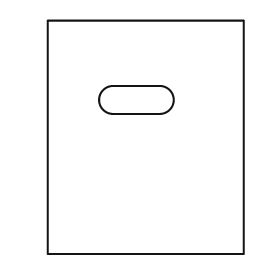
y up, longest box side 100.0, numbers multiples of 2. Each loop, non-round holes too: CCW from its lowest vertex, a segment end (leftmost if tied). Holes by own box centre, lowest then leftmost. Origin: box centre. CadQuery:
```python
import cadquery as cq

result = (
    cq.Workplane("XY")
    .moveTo(-42.0, -50.0)
    .lineTo(42.0, -50.0)
    .lineTo(42.0, 50.0)
    .lineTo(-42.0, 50.0)
    .close()
    .moveTo(-14.0, 10.0)
    .lineTo(6.0, 10.0)
    .threePointArc((12.0, 16.0), (6.0, 22.0))
    .lineTo(-14.0, 22.0)
    .threePointArc((-20.0, 16.0), (-14.0, 10.0))
    .close()
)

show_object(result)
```